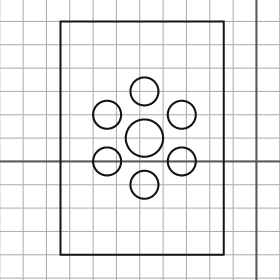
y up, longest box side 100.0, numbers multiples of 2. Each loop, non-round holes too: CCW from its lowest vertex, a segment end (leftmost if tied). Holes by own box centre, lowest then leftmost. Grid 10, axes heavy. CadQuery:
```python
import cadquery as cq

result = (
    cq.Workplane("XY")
    .moveTo(-84.0, -40.0)
    .lineTo(-14.0, -40.0)
    .lineTo(-14.0, 60.0)
    .lineTo(-84.0, 60.0)
    .close()
    .moveTo(-48.0, -10.0)
    .circle(6.0)
    .moveTo(-64.0, 0.0)
    .circle(6.0)
    .moveTo(-32.0, 0.0)
    .circle(6.0)
    .moveTo(-48.0, 10.0)
    .circle(8.0)
    .moveTo(-64.0, 20.0)
    .circle(6.0)
    .moveTo(-32.0, 20.0)
    .circle(6.0)
    .moveTo(-48.0, 30.0)
    .circle(6.0)
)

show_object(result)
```